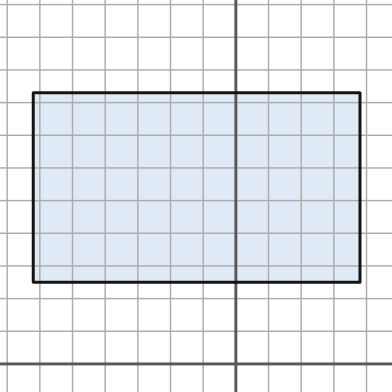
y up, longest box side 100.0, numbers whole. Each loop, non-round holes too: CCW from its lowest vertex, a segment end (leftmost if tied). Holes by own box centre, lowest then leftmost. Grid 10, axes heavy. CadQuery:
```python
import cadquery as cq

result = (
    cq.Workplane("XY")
    .moveTo(-62.0, 25.0)
    .lineTo(38.0, 25.0)
    .lineTo(38.0, 83.0)
    .lineTo(-62.0, 83.0)
    .close()
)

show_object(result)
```